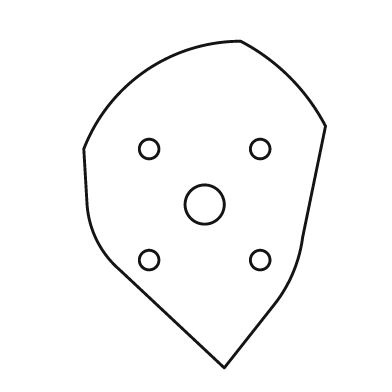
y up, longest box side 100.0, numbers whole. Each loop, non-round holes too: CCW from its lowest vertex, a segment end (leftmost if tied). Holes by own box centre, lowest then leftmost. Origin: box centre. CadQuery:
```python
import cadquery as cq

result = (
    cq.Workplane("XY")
    .moveTo(6.0, -50.0)
    .lineTo(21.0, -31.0)
    .threePointArc((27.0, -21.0), (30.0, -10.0))
    .lineTo(37.0, 24.0)
    .threePointArc((26.0, 39.0), (11.0, 50.0))
    .threePointArc((-18.0, 41.0), (-37.0, 17.0))
    .lineTo(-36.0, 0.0)
    .threePointArc((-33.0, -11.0), (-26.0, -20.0))
    .close()
    .moveTo(-17.0, -17.0)
    .circle(3.0)
    .moveTo(17.0, -17.0)
    .circle(3.0)
    .moveTo(0.0, 0.0)
    .circle(6.0)
    .moveTo(-17.0, 17.0)
    .circle(3.0)
    .moveTo(17.0, 17.0)
    .circle(3.0)
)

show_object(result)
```